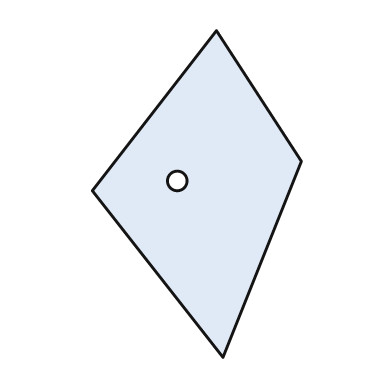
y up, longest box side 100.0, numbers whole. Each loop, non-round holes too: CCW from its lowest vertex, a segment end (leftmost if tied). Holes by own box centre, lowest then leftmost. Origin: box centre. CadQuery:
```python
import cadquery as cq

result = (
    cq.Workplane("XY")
    .moveTo(8.0, -50.0)
    .lineTo(32.0, 10.0)
    .lineTo(6.0, 50.0)
    .lineTo(-32.0, 1.0)
    .close()
    .moveTo(-6.0, 4.0)
    .circle(3.0)
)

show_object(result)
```